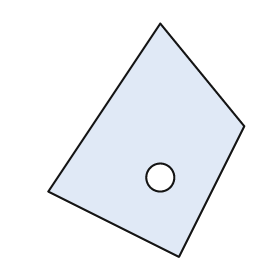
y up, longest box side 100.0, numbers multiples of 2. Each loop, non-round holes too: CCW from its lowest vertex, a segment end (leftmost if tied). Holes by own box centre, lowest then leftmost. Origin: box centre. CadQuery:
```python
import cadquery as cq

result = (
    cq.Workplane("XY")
    .moveTo(14.0, -50.0)
    .lineTo(42.0, 6.0)
    .lineTo(6.0, 50.0)
    .lineTo(-42.0, -22.0)
    .close()
    .moveTo(6.0, -16.0)
    .circle(6.0)
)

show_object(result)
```